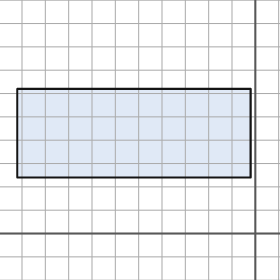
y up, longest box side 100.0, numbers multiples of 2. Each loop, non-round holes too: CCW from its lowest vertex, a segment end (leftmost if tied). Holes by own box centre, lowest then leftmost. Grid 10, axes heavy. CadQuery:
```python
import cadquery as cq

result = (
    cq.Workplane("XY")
    .moveTo(-102.0, 24.0)
    .lineTo(-2.0, 24.0)
    .lineTo(-2.0, 62.0)
    .lineTo(-102.0, 62.0)
    .close()
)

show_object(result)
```